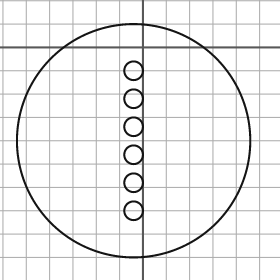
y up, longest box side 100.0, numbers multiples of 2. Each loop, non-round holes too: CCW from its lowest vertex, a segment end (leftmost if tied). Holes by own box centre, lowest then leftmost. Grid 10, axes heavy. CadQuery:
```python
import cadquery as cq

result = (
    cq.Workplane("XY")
    .moveTo(-4.0, -40.0)
    .circle(50.0)
    .moveTo(-4.0, -70.0)
    .circle(4.0)
    .moveTo(-4.0, -58.0)
    .circle(4.0)
    .moveTo(-4.0, -46.0)
    .circle(4.0)
    .moveTo(-4.0, -34.0)
    .circle(4.0)
    .moveTo(-4.0, -22.0)
    .circle(4.0)
    .moveTo(-4.0, -10.0)
    .circle(4.0)
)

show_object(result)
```